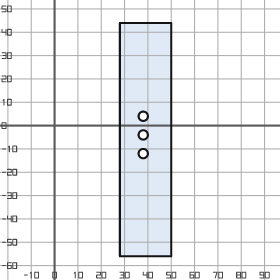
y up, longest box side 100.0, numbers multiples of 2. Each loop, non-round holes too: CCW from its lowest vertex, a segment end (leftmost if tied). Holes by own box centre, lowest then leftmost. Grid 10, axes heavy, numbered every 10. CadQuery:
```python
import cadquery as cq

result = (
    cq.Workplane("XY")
    .moveTo(28.0, -56.0)
    .lineTo(50.0, -56.0)
    .lineTo(50.0, 44.0)
    .lineTo(28.0, 44.0)
    .close()
    .moveTo(38.0, -12.0)
    .circle(2.0)
    .moveTo(38.0, -4.0)
    .circle(2.0)
    .moveTo(38.0, 4.0)
    .circle(2.0)
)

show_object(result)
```